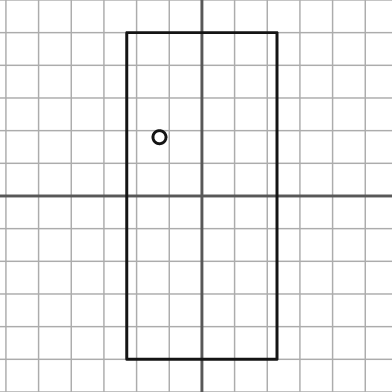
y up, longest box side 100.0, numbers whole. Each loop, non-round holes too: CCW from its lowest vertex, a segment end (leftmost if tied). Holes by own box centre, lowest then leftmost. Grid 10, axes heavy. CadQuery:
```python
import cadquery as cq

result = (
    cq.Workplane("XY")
    .moveTo(-23.0, -50.0)
    .lineTo(23.0, -50.0)
    .lineTo(23.0, 50.0)
    .lineTo(-23.0, 50.0)
    .close()
    .moveTo(-13.0, 18.0)
    .circle(2.0)
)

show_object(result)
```